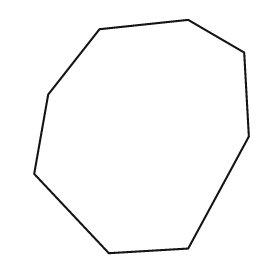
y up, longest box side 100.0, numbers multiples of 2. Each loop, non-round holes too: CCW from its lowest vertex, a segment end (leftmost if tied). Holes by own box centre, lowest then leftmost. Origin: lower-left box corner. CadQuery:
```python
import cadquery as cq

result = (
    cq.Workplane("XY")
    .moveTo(32.0, 0.0)
    .lineTo(66.0, 2.0)
    .lineTo(92.0, 50.0)
    .lineTo(90.0, 86.0)
    .lineTo(66.0, 100.0)
    .lineTo(28.0, 96.0)
    .lineTo(6.0, 68.0)
    .lineTo(0.0, 34.0)
    .close()
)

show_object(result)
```